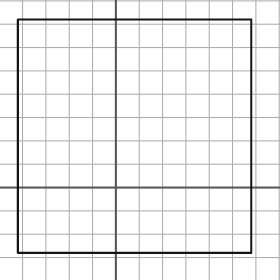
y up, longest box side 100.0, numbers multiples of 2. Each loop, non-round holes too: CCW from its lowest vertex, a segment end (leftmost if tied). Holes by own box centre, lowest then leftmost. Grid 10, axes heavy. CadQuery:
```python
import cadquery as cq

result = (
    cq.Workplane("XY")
    .moveTo(-42.0, -28.0)
    .lineTo(58.0, -28.0)
    .lineTo(58.0, 72.0)
    .lineTo(-42.0, 72.0)
    .close()
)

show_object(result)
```